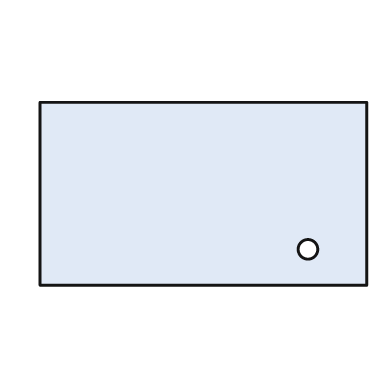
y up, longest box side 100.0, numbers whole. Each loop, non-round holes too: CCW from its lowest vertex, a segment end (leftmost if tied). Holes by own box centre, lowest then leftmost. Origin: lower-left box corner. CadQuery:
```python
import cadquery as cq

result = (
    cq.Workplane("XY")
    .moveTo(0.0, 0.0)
    .lineTo(100.0, 0.0)
    .lineTo(100.0, 56.0)
    .lineTo(0.0, 56.0)
    .close()
    .moveTo(82.0, 11.0)
    .circle(3.0)
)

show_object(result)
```